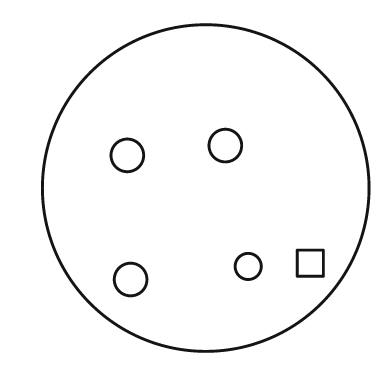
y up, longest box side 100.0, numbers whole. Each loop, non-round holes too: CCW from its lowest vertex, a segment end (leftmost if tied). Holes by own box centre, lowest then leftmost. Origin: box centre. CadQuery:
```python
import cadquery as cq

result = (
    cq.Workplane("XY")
    .moveTo(0.0, 0.0)
    .circle(50.0)
    .moveTo(-23.0, -28.0)
    .circle(5.0)
    .moveTo(13.0, -24.0)
    .circle(4.0)
    .moveTo(28.0, -27.0)
    .lineTo(36.0, -27.0)
    .lineTo(36.0, -19.0)
    .lineTo(28.0, -19.0)
    .close()
    .moveTo(-24.0, 10.0)
    .circle(5.0)
    .moveTo(6.0, 13.0)
    .circle(5.0)
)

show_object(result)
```